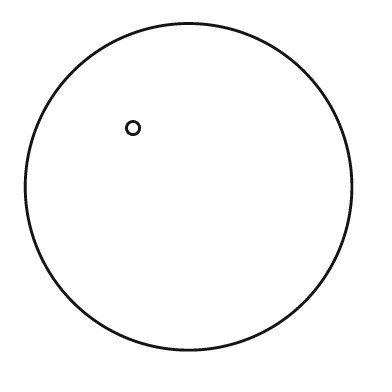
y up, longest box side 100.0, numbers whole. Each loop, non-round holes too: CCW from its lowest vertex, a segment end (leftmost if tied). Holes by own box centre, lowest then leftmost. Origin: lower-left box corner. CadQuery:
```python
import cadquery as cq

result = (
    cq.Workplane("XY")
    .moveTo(50.0, 50.0)
    .circle(50.0)
    .moveTo(33.0, 68.0)
    .circle(2.0)
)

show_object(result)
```